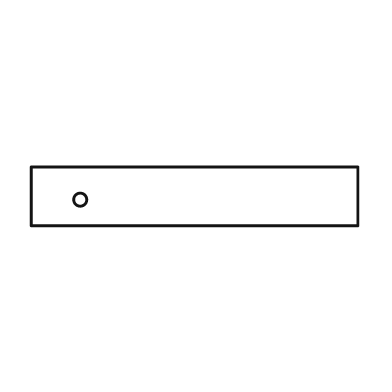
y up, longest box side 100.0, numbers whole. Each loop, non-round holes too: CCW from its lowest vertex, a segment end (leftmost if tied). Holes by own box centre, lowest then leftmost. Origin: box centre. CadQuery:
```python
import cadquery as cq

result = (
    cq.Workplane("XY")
    .moveTo(-50.0, -9.0)
    .lineTo(50.0, -9.0)
    .lineTo(50.0, 9.0)
    .lineTo(-50.0, 9.0)
    .close()
    .moveTo(-35.0, -1.0)
    .circle(2.0)
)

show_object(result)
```